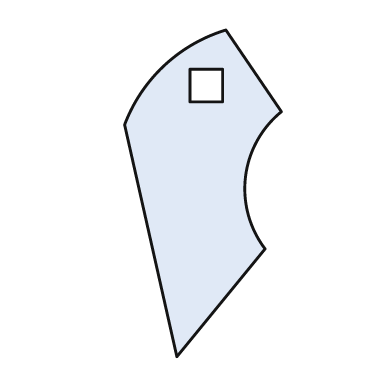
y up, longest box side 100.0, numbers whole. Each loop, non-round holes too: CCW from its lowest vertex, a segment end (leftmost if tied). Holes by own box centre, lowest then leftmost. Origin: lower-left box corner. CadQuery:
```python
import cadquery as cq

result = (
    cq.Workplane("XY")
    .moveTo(16.0, 0.0)
    .lineTo(43.0, 33.0)
    .threePointArc((37.0, 55.0), (48.0, 75.0))
    .lineTo(31.0, 100.0)
    .threePointArc((12.0, 89.0), (0.0, 71.0))
    .close()
    .moveTo(20.0, 78.0)
    .lineTo(30.0, 78.0)
    .lineTo(30.0, 88.0)
    .lineTo(20.0, 88.0)
    .close()
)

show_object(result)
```